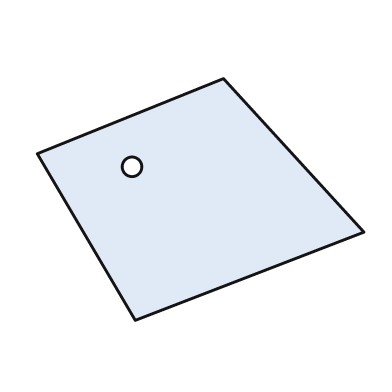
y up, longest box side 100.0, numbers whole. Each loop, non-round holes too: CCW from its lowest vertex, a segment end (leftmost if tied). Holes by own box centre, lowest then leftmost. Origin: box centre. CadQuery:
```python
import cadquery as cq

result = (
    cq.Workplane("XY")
    .moveTo(-20.0, -37.0)
    .lineTo(50.0, -10.0)
    .lineTo(7.0, 37.0)
    .lineTo(-50.0, 14.0)
    .close()
    .moveTo(-21.0, 10.0)
    .circle(3.0)
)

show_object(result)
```